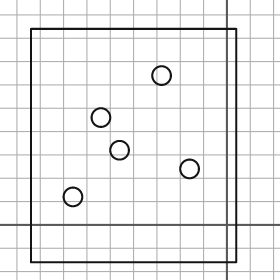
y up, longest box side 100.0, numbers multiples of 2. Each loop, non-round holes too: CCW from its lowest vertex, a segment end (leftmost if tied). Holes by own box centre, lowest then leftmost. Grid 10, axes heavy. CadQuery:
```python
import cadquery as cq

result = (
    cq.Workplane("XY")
    .moveTo(-84.0, -16.0)
    .lineTo(4.0, -16.0)
    .lineTo(4.0, 84.0)
    .lineTo(-84.0, 84.0)
    .close()
    .moveTo(-66.0, 12.0)
    .circle(4.0)
    .moveTo(-16.0, 24.0)
    .circle(4.0)
    .moveTo(-46.0, 32.0)
    .circle(4.0)
    .moveTo(-54.0, 46.0)
    .circle(4.0)
    .moveTo(-28.0, 64.0)
    .circle(4.0)
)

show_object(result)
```